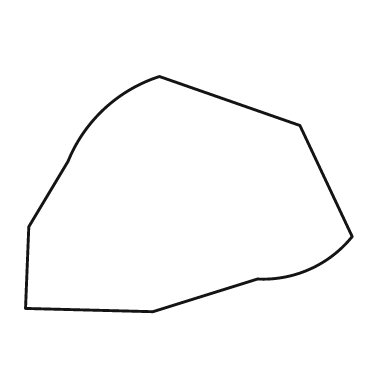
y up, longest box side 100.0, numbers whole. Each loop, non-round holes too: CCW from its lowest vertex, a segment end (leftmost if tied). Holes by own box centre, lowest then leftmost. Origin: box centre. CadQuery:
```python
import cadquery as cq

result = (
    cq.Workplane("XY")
    .moveTo(-11.0, -36.0)
    .lineTo(21.0, -26.0)
    .threePointArc((37.0, -23.0), (50.0, -13.0))
    .lineTo(34.0, 21.0)
    .lineTo(-9.0, 36.0)
    .threePointArc((-26.0, 26.0), (-37.0, 10.0))
    .lineTo(-49.0, -10.0)
    .lineTo(-50.0, -35.0)
    .close()
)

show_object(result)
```